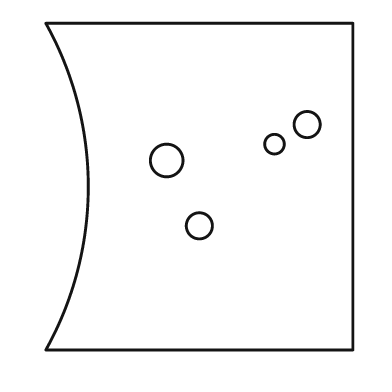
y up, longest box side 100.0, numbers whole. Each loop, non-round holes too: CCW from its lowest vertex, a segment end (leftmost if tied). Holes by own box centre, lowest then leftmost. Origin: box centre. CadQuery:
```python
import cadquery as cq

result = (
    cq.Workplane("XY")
    .moveTo(-47.0, -50.0)
    .lineTo(47.0, -50.0)
    .lineTo(47.0, 50.0)
    .lineTo(-47.0, 50.0)
    .threePointArc((-34.0, 0.0), (-47.0, -50.0))
    .close()
    .moveTo(0.0, -12.0)
    .circle(4.0)
    .moveTo(-10.0, 8.0)
    .circle(5.0)
    .moveTo(23.0, 13.0)
    .circle(3.0)
    .moveTo(33.0, 19.0)
    .circle(4.0)
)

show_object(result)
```